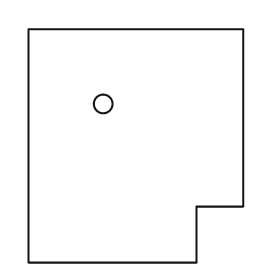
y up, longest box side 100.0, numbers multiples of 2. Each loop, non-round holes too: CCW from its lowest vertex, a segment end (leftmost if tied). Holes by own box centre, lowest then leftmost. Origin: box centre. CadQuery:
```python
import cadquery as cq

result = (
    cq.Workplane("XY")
    .moveTo(-46.0, -50.0)
    .lineTo(26.0, -50.0)
    .lineTo(26.0, -26.0)
    .lineTo(46.0, -26.0)
    .lineTo(46.0, 50.0)
    .lineTo(-46.0, 50.0)
    .close()
    .moveTo(-14.0, 18.0)
    .circle(4.0)
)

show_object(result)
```